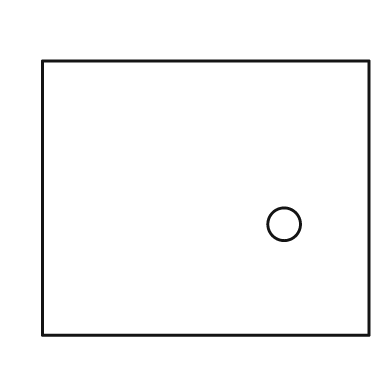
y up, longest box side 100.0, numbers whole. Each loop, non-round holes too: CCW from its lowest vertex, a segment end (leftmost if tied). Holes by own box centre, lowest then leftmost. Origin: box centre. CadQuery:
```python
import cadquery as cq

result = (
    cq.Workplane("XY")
    .moveTo(-50.0, -42.0)
    .lineTo(50.0, -42.0)
    .lineTo(50.0, 42.0)
    .lineTo(-50.0, 42.0)
    .close()
    .moveTo(24.0, -8.0)
    .circle(5.0)
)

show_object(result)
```